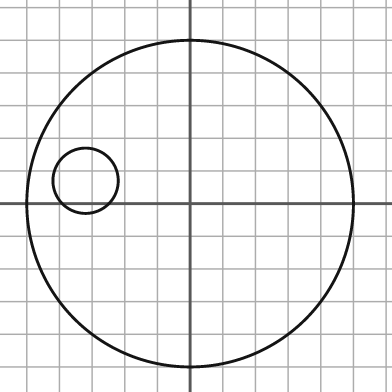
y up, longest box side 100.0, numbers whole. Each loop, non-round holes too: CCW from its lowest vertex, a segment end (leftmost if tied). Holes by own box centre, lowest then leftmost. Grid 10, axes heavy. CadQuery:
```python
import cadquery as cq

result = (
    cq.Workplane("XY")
    .moveTo(0.0, 0.0)
    .circle(50.0)
    .moveTo(-32.0, 7.0)
    .circle(10.0)
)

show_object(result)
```